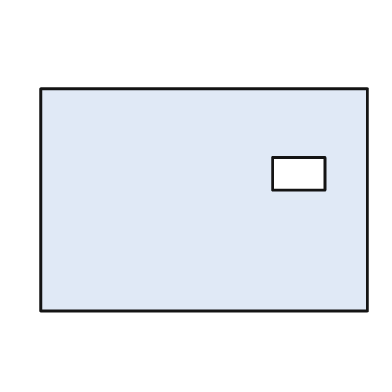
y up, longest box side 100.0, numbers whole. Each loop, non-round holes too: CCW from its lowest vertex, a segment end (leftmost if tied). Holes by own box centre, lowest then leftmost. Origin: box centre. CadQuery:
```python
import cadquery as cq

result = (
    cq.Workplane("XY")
    .moveTo(-50.0, -34.0)
    .lineTo(50.0, -34.0)
    .lineTo(50.0, 34.0)
    .lineTo(-50.0, 34.0)
    .close()
    .moveTo(21.0, 3.0)
    .lineTo(37.0, 3.0)
    .lineTo(37.0, 13.0)
    .lineTo(21.0, 13.0)
    .close()
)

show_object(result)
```